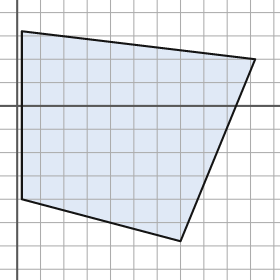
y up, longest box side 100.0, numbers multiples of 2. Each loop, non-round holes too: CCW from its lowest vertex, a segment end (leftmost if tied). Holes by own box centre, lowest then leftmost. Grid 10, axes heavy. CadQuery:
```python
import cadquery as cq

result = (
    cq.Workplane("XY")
    .moveTo(70.0, -58.0)
    .lineTo(102.0, 20.0)
    .lineTo(2.0, 32.0)
    .lineTo(2.0, -40.0)
    .close()
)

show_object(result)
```